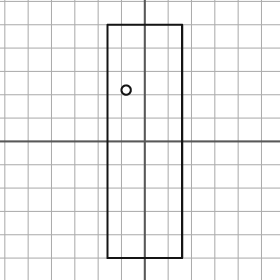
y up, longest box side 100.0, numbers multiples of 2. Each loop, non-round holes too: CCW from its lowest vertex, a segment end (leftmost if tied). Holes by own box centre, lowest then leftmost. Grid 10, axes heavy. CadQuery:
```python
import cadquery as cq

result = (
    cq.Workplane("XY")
    .moveTo(-16.0, -50.0)
    .lineTo(16.0, -50.0)
    .lineTo(16.0, 50.0)
    .lineTo(-16.0, 50.0)
    .close()
    .moveTo(-8.0, 22.0)
    .circle(2.0)
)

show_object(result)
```